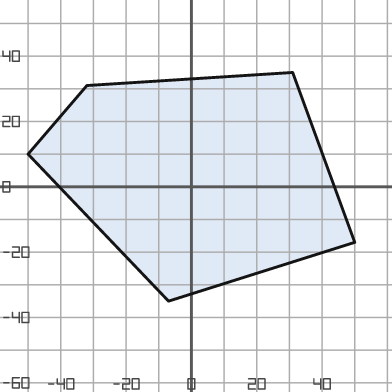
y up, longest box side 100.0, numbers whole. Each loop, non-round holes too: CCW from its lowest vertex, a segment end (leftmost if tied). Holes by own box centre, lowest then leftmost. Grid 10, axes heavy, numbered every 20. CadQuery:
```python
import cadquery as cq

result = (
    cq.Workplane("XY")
    .moveTo(-7.0, -35.0)
    .lineTo(50.0, -17.0)
    .lineTo(31.0, 35.0)
    .lineTo(-32.0, 31.0)
    .lineTo(-50.0, 10.0)
    .close()
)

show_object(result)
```